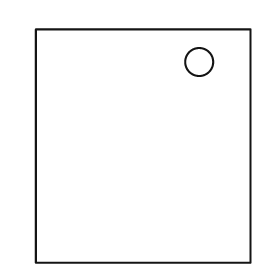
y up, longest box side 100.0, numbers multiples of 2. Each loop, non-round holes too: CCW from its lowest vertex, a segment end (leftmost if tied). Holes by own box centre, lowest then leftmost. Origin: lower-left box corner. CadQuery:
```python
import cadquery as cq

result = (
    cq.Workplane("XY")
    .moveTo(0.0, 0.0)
    .lineTo(92.0, 0.0)
    .lineTo(92.0, 100.0)
    .lineTo(0.0, 100.0)
    .close()
    .moveTo(70.0, 86.0)
    .circle(6.0)
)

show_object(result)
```